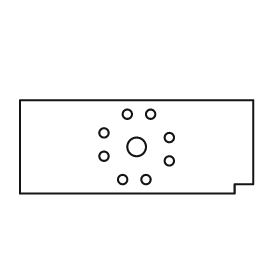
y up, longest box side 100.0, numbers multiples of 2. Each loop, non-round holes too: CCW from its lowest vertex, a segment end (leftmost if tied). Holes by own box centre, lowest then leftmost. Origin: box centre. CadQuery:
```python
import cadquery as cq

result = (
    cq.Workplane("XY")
    .moveTo(-50.0, -20.0)
    .lineTo(42.0, -20.0)
    .lineTo(42.0, -16.0)
    .lineTo(50.0, -16.0)
    .lineTo(50.0, 20.0)
    .lineTo(-50.0, 20.0)
    .close()
    .moveTo(-6.0, -14.0)
    .circle(2.0)
    .moveTo(4.0, -14.0)
    .circle(2.0)
    .moveTo(14.0, -6.0)
    .circle(2.0)
    .moveTo(-14.0, -4.0)
    .circle(2.0)
    .moveTo(0.0, 0.0)
    .circle(4.0)
    .moveTo(14.0, 4.0)
    .circle(2.0)
    .moveTo(-14.0, 6.0)
    .circle(2.0)
    .moveTo(-4.0, 14.0)
    .circle(2.0)
    .moveTo(6.0, 14.0)
    .circle(2.0)
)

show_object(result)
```